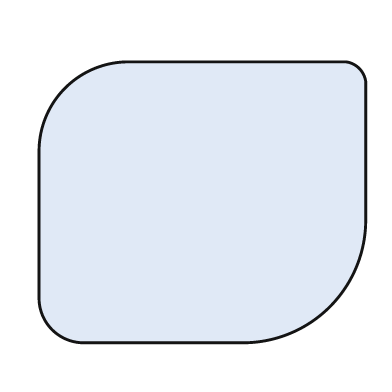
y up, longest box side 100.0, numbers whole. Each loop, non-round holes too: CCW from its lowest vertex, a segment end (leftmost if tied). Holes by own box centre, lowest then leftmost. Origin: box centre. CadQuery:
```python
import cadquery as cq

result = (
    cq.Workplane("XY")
    .moveTo(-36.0, -43.0)
    .lineTo(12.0, -43.0)
    .threePointArc((39.0, -32.0), (50.0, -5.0))
    .lineTo(50.0, 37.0)
    .threePointArc((48.0, 41.0), (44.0, 43.0))
    .lineTo(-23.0, 43.0)
    .threePointArc((-42.0, 35.0), (-50.0, 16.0))
    .lineTo(-50.0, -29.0)
    .threePointArc((-46.0, -39.0), (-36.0, -43.0))
    .close()
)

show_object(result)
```